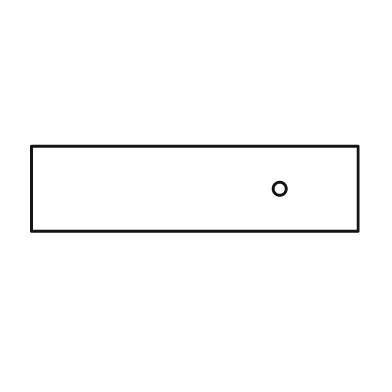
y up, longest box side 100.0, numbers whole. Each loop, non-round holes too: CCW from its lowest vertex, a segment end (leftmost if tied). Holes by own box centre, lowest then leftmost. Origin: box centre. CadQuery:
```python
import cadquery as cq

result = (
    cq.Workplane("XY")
    .moveTo(-50.0, -13.0)
    .lineTo(50.0, -13.0)
    .lineTo(50.0, 13.0)
    .lineTo(-50.0, 13.0)
    .close()
    .moveTo(26.0, 0.0)
    .circle(2.0)
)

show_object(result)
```